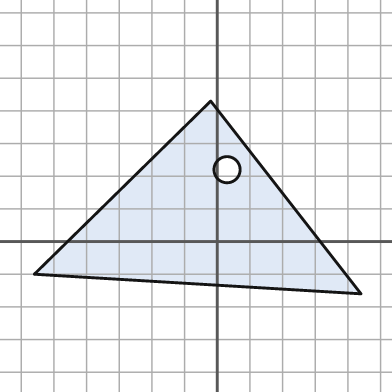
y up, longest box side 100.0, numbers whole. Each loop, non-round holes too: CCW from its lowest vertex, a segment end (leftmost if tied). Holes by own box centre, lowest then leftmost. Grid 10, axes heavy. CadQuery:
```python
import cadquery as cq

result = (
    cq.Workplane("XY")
    .moveTo(44.0, -16.0)
    .lineTo(-2.0, 43.0)
    .lineTo(-56.0, -10.0)
    .close()
    .moveTo(3.0, 22.0)
    .circle(4.0)
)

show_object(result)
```